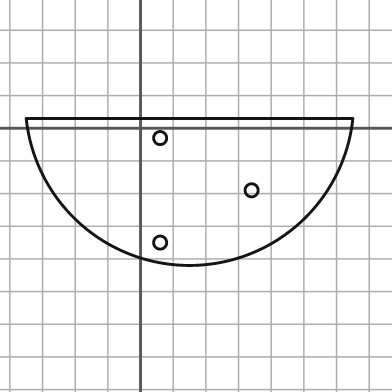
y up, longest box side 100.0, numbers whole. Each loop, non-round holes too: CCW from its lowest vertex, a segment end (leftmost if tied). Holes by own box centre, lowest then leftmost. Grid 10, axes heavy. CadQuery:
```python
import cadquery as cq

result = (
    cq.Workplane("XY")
    .moveTo(-35.0, 3.0)
    .threePointArc((15.0, -42.0), (65.0, 3.0))
    .close()
    .moveTo(6.0, -35.0)
    .circle(2.0)
    .moveTo(34.0, -19.0)
    .circle(2.0)
    .moveTo(6.0, -3.0)
    .circle(2.0)
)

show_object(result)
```